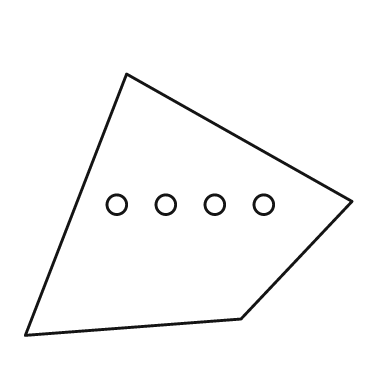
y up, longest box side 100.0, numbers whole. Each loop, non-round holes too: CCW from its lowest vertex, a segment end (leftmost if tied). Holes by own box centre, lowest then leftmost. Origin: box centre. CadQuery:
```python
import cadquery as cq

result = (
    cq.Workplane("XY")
    .moveTo(-50.0, -40.0)
    .lineTo(16.0, -35.0)
    .lineTo(50.0, 1.0)
    .lineTo(-19.0, 40.0)
    .close()
    .moveTo(-22.0, 0.0)
    .circle(3.0)
    .moveTo(-7.0, 0.0)
    .circle(3.0)
    .moveTo(8.0, 0.0)
    .circle(3.0)
    .moveTo(23.0, 0.0)
    .circle(3.0)
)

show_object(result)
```